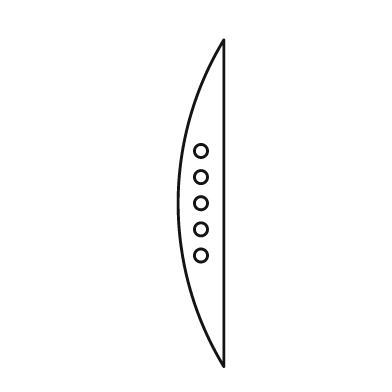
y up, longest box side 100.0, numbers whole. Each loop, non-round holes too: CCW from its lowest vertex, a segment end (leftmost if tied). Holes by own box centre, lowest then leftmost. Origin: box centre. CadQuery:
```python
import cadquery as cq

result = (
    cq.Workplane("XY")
    .moveTo(7.0, -50.0)
    .lineTo(7.0, 50.0)
    .threePointArc((-7.0, 0.0), (7.0, -50.0))
    .close()
    .moveTo(0.0, -16.0)
    .circle(2.0)
    .moveTo(0.0, -8.0)
    .circle(2.0)
    .moveTo(0.0, 0.0)
    .circle(2.0)
    .moveTo(0.0, 8.0)
    .circle(2.0)
    .moveTo(0.0, 16.0)
    .circle(2.0)
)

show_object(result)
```